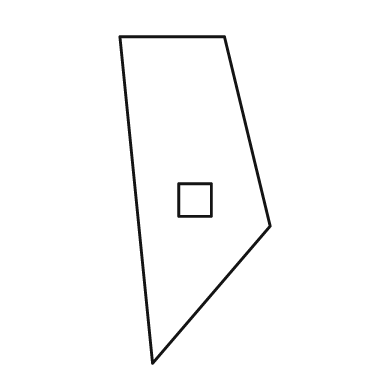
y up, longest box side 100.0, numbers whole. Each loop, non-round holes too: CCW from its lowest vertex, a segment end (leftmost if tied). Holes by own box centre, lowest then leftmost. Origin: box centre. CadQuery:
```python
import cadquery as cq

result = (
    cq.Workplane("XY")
    .moveTo(-13.0, -50.0)
    .lineTo(23.0, -8.0)
    .lineTo(9.0, 50.0)
    .lineTo(-23.0, 50.0)
    .close()
    .moveTo(-5.0, -5.0)
    .lineTo(5.0, -5.0)
    .lineTo(5.0, 5.0)
    .lineTo(-5.0, 5.0)
    .close()
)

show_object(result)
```